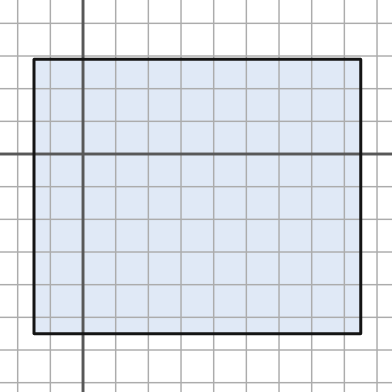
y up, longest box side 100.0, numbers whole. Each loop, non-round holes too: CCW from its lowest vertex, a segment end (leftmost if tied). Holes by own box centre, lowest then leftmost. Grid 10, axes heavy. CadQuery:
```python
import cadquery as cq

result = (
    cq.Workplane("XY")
    .moveTo(-15.0, -55.0)
    .lineTo(85.0, -55.0)
    .lineTo(85.0, 29.0)
    .lineTo(-15.0, 29.0)
    .close()
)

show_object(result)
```